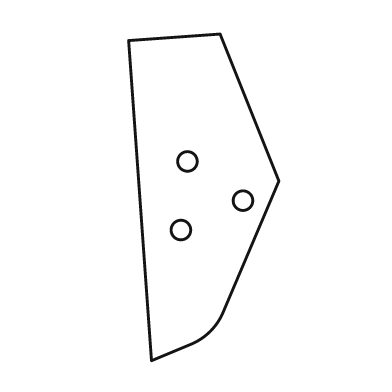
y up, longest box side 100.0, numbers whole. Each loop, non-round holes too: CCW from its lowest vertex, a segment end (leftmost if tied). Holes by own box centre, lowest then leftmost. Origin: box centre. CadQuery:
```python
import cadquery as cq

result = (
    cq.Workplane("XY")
    .moveTo(-16.0, -50.0)
    .lineTo(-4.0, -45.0)
    .threePointArc((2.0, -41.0), (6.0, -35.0))
    .lineTo(23.0, 5.0)
    .lineTo(5.0, 50.0)
    .lineTo(-23.0, 48.0)
    .close()
    .moveTo(-7.0, -10.0)
    .circle(3.0)
    .moveTo(12.0, -1.0)
    .circle(3.0)
    .moveTo(-5.0, 11.0)
    .circle(3.0)
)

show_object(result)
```